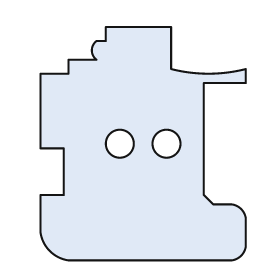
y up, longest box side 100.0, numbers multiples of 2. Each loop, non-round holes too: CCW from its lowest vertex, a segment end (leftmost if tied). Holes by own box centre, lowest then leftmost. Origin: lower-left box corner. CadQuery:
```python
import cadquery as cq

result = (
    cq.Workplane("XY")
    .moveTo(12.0, 0.0)
    .lineTo(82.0, 0.0)
    .threePointArc((86.0, 2.0), (88.0, 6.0))
    .lineTo(88.0, 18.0)
    .threePointArc((86.0, 22.0), (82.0, 24.0))
    .lineTo(74.0, 24.0)
    .lineTo(70.0, 28.0)
    .lineTo(70.0, 76.0)
    .lineTo(88.0, 76.0)
    .lineTo(88.0, 82.0)
    .threePointArc((72.0, 80.0), (56.0, 82.0))
    .lineTo(56.0, 100.0)
    .lineTo(28.0, 100.0)
    .lineTo(28.0, 94.0)
    .lineTo(24.0, 94.0)
    .threePointArc((22.0, 90.0), (24.0, 86.0))
    .lineTo(12.0, 86.0)
    .lineTo(12.0, 80.0)
    .lineTo(0.0, 80.0)
    .lineTo(0.0, 48.0)
    .lineTo(10.0, 48.0)
    .lineTo(10.0, 28.0)
    .lineTo(0.0, 28.0)
    .lineTo(0.0, 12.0)
    .threePointArc((4.0, 4.0), (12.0, 0.0))
    .close()
    .moveTo(34.0, 50.0)
    .circle(6.0)
    .moveTo(54.0, 50.0)
    .circle(6.0)
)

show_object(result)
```